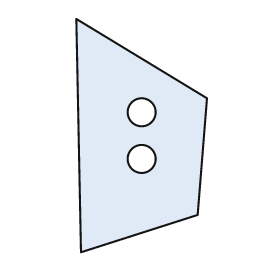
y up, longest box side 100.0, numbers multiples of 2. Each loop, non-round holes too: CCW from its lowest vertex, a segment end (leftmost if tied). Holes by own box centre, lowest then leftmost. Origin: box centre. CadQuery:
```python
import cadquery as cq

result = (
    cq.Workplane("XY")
    .moveTo(-26.0, -50.0)
    .lineTo(24.0, -34.0)
    .lineTo(28.0, 16.0)
    .lineTo(-28.0, 50.0)
    .close()
    .moveTo(0.0, -10.0)
    .circle(6.0)
    .moveTo(0.0, 10.0)
    .circle(6.0)
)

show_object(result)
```